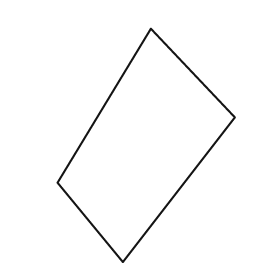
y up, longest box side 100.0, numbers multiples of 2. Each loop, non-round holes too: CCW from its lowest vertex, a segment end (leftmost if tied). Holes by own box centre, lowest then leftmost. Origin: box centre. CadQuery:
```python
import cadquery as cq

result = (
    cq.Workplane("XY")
    .moveTo(-10.0, -50.0)
    .lineTo(38.0, 12.0)
    .lineTo(2.0, 50.0)
    .lineTo(-38.0, -16.0)
    .close()
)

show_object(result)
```